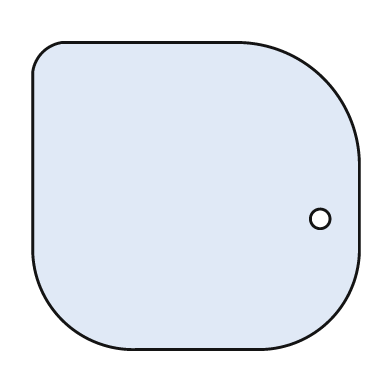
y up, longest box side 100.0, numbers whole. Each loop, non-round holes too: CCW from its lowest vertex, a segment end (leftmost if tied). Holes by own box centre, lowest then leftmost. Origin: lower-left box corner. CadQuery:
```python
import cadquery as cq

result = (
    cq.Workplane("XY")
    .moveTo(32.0, 0.0)
    .lineTo(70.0, 0.0)
    .threePointArc((91.0, 9.0), (100.0, 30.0))
    .lineTo(100.0, 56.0)
    .threePointArc((89.0, 83.0), (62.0, 94.0))
    .lineTo(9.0, 94.0)
    .threePointArc((3.0, 91.0), (0.0, 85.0))
    .lineTo(0.0, 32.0)
    .threePointArc((9.0, 9.0), (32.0, 0.0))
    .close()
    .moveTo(88.0, 40.0)
    .circle(3.0)
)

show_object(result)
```